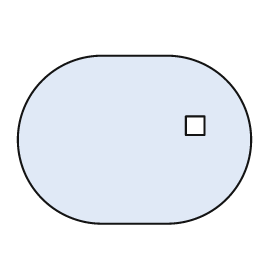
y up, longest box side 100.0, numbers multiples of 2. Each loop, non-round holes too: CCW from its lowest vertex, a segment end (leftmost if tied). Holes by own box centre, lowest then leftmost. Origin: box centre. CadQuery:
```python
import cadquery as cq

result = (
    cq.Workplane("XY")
    .moveTo(-14.0, -36.0)
    .lineTo(14.0, -36.0)
    .threePointArc((50.0, 0.0), (14.0, 36.0))
    .lineTo(-14.0, 36.0)
    .threePointArc((-50.0, 0.0), (-14.0, -36.0))
    .close()
    .moveTo(22.0, 2.0)
    .lineTo(30.0, 2.0)
    .lineTo(30.0, 10.0)
    .lineTo(22.0, 10.0)
    .close()
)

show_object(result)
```